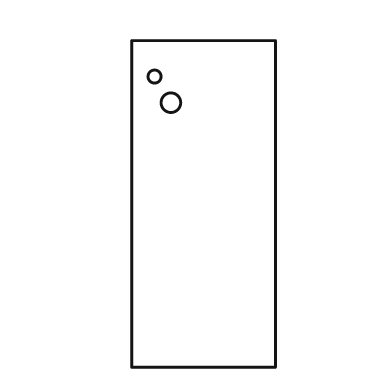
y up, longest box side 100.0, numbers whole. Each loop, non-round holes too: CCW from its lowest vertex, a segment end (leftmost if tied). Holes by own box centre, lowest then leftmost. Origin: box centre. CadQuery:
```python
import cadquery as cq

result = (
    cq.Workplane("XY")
    .moveTo(-22.0, -50.0)
    .lineTo(22.0, -50.0)
    .lineTo(22.0, 50.0)
    .lineTo(-22.0, 50.0)
    .close()
    .moveTo(-10.0, 31.0)
    .circle(3.0)
    .moveTo(-15.0, 39.0)
    .circle(2.0)
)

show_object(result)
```